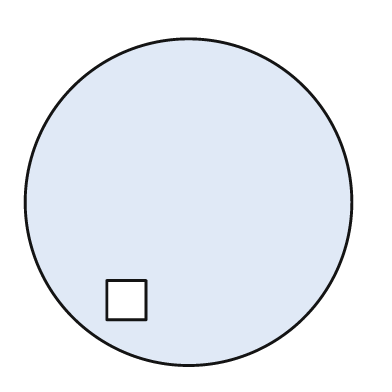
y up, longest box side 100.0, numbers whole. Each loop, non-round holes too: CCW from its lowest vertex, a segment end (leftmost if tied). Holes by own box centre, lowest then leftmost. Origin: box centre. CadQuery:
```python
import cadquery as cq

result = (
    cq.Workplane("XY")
    .moveTo(0.0, 0.0)
    .circle(50.0)
    .moveTo(-25.0, -36.0)
    .lineTo(-13.0, -36.0)
    .lineTo(-13.0, -24.0)
    .lineTo(-25.0, -24.0)
    .close()
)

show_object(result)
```